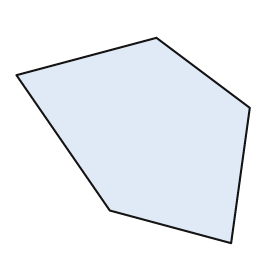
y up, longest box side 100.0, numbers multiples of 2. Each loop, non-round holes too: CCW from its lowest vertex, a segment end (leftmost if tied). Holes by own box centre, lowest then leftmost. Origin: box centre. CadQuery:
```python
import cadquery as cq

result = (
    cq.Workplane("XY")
    .moveTo(42.0, -44.0)
    .lineTo(50.0, 14.0)
    .lineTo(10.0, 44.0)
    .lineTo(-50.0, 28.0)
    .lineTo(-10.0, -30.0)
    .close()
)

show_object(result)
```